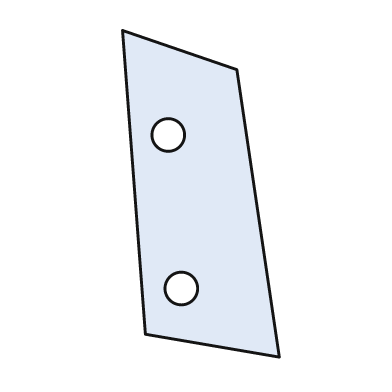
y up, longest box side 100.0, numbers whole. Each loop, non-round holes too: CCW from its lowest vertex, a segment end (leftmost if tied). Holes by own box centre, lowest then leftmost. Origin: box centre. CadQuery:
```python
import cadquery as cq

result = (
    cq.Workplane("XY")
    .moveTo(24.0, -50.0)
    .lineTo(11.0, 38.0)
    .lineTo(-24.0, 50.0)
    .lineTo(-17.0, -43.0)
    .close()
    .moveTo(-6.0, -29.0)
    .circle(5.0)
    .moveTo(-10.0, 18.0)
    .circle(5.0)
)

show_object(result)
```